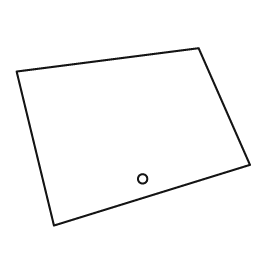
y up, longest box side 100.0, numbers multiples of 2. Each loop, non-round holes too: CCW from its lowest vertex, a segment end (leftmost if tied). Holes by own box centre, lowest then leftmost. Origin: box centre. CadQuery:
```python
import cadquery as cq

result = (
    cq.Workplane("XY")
    .moveTo(-34.0, -38.0)
    .lineTo(50.0, -12.0)
    .lineTo(28.0, 38.0)
    .lineTo(-50.0, 28.0)
    .close()
    .moveTo(4.0, -18.0)
    .circle(2.0)
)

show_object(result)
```